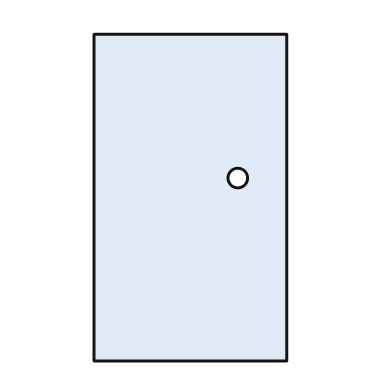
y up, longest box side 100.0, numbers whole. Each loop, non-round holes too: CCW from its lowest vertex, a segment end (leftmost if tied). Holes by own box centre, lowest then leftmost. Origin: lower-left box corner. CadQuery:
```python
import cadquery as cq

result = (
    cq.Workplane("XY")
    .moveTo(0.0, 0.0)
    .lineTo(59.0, 0.0)
    .lineTo(59.0, 100.0)
    .lineTo(0.0, 100.0)
    .close()
    .moveTo(44.0, 56.0)
    .circle(3.0)
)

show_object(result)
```